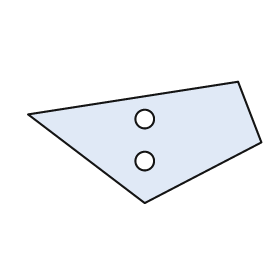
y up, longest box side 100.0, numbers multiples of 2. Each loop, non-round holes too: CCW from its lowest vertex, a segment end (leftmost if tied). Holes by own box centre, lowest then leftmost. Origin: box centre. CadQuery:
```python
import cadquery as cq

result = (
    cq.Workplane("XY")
    .moveTo(0.0, -26.0)
    .lineTo(50.0, 0.0)
    .lineTo(40.0, 26.0)
    .lineTo(-50.0, 12.0)
    .close()
    .moveTo(0.0, -8.0)
    .circle(4.0)
    .moveTo(0.0, 10.0)
    .circle(4.0)
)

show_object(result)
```